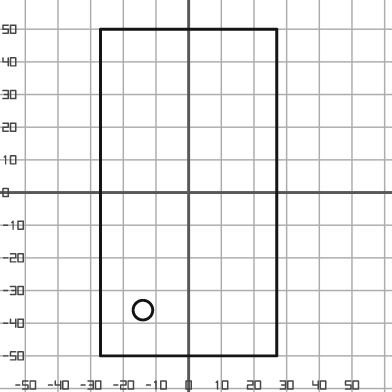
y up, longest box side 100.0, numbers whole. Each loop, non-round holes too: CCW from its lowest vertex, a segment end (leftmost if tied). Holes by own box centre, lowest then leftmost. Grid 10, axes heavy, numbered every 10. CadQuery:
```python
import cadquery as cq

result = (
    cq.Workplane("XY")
    .moveTo(-27.0, -50.0)
    .lineTo(27.0, -50.0)
    .lineTo(27.0, 50.0)
    .lineTo(-27.0, 50.0)
    .close()
    .moveTo(-14.0, -36.0)
    .circle(3.0)
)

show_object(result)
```